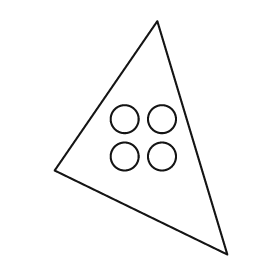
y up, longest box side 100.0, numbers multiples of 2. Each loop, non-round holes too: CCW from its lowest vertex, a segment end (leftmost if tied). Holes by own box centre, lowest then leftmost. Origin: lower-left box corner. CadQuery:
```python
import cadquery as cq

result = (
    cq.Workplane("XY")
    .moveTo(74.0, 0.0)
    .lineTo(44.0, 100.0)
    .lineTo(0.0, 36.0)
    .close()
    .moveTo(30.0, 42.0)
    .circle(6.0)
    .moveTo(46.0, 42.0)
    .circle(6.0)
    .moveTo(30.0, 58.0)
    .circle(6.0)
    .moveTo(46.0, 58.0)
    .circle(6.0)
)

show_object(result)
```